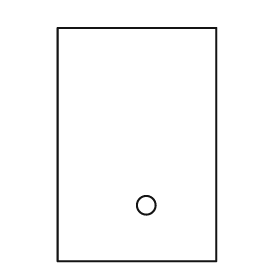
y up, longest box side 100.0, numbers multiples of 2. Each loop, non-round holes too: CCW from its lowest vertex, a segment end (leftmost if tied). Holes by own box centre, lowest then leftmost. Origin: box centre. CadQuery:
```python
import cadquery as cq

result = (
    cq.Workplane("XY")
    .moveTo(-34.0, -50.0)
    .lineTo(34.0, -50.0)
    .lineTo(34.0, 50.0)
    .lineTo(-34.0, 50.0)
    .close()
    .moveTo(4.0, -26.0)
    .circle(4.0)
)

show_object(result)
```